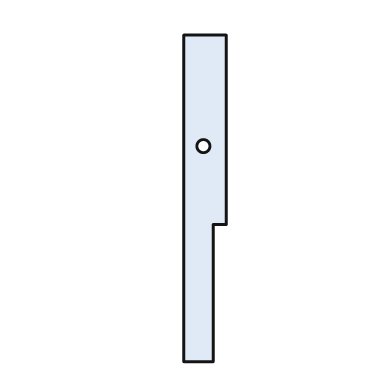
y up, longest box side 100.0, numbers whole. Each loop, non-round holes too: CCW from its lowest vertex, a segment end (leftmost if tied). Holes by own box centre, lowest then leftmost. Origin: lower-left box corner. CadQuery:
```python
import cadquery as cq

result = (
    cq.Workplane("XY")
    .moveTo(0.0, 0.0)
    .lineTo(9.0, 0.0)
    .lineTo(9.0, 42.0)
    .lineTo(13.0, 42.0)
    .lineTo(13.0, 100.0)
    .lineTo(0.0, 100.0)
    .close()
    .moveTo(6.0, 66.0)
    .circle(2.0)
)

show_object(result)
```